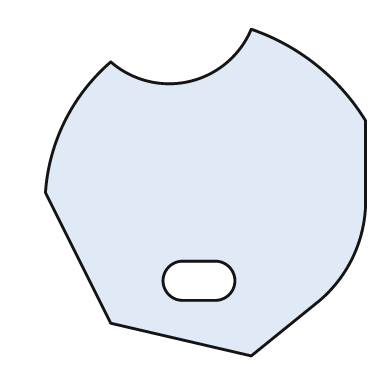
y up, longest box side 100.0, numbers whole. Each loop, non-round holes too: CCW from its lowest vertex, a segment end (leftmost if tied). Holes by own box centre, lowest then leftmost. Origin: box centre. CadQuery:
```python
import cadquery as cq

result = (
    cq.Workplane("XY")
    .moveTo(14.0, -50.0)
    .lineTo(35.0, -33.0)
    .threePointArc((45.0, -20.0), (49.0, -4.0))
    .lineTo(49.0, 22.0)
    .threePointArc((34.0, 39.0), (14.0, 50.0))
    .threePointArc((-5.0, 34.0), (-29.0, 40.0))
    .threePointArc((-43.0, 22.0), (-49.0, 0.0))
    .lineTo(-29.0, -40.0)
    .close()
    .moveTo(-7.0, -33.0)
    .lineTo(3.0, -33.0)
    .threePointArc((9.0, -27.0), (3.0, -21.0))
    .lineTo(-7.0, -21.0)
    .threePointArc((-13.0, -27.0), (-7.0, -33.0))
    .close()
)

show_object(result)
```